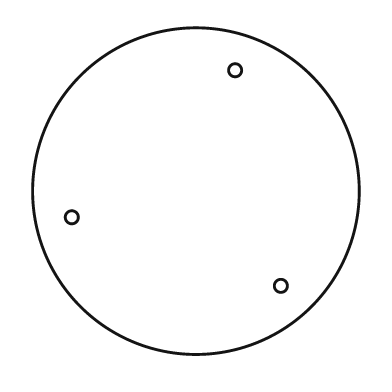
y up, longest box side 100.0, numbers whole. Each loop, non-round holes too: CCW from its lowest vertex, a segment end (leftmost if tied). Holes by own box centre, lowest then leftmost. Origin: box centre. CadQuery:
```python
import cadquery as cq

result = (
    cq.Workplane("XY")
    .moveTo(0.0, 0.0)
    .circle(50.0)
    .moveTo(26.0, -29.0)
    .circle(2.0)
    .moveTo(-38.0, -8.0)
    .circle(2.0)
    .moveTo(12.0, 37.0)
    .circle(2.0)
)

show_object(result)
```